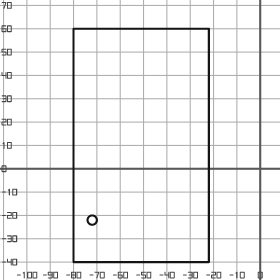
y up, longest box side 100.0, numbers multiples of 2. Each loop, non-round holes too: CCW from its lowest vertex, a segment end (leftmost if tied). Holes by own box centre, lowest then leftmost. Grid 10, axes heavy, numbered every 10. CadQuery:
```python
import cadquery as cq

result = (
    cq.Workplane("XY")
    .moveTo(-80.0, -40.0)
    .lineTo(-22.0, -40.0)
    .lineTo(-22.0, 60.0)
    .lineTo(-80.0, 60.0)
    .close()
    .moveTo(-72.0, -22.0)
    .circle(2.0)
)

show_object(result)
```